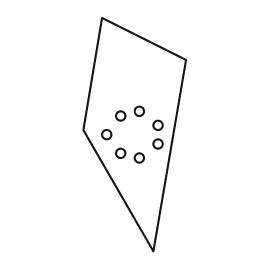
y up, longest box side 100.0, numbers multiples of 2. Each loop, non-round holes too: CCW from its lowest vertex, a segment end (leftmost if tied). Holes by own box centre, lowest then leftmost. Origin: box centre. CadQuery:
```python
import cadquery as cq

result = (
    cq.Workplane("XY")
    .moveTo(8.0, -50.0)
    .lineTo(22.0, 32.0)
    .lineTo(-14.0, 50.0)
    .lineTo(-22.0, 2.0)
    .close()
    .moveTo(2.0, -10.0)
    .circle(2.0)
    .moveTo(-6.0, -8.0)
    .circle(2.0)
    .moveTo(10.0, -4.0)
    .circle(2.0)
    .moveTo(-12.0, 0.0)
    .circle(2.0)
    .moveTo(10.0, 4.0)
    .circle(2.0)
    .moveTo(-6.0, 8.0)
    .circle(2.0)
    .moveTo(2.0, 10.0)
    .circle(2.0)
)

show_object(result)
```